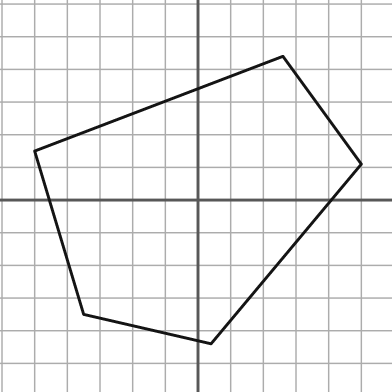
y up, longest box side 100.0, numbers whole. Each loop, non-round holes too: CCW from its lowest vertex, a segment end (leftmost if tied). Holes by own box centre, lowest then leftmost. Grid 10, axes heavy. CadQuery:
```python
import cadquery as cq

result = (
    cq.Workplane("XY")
    .moveTo(4.0, -44.0)
    .lineTo(50.0, 11.0)
    .lineTo(26.0, 44.0)
    .lineTo(-50.0, 15.0)
    .lineTo(-35.0, -35.0)
    .close()
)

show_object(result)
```